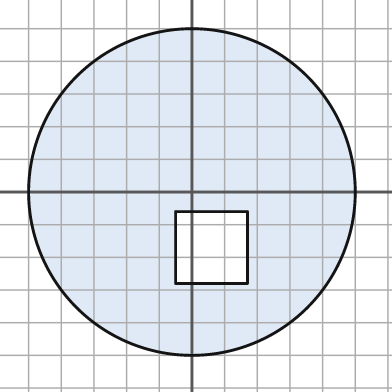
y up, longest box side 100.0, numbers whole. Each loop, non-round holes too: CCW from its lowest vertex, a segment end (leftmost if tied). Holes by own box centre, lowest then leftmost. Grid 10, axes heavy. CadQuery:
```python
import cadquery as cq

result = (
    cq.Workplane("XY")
    .moveTo(0.0, 0.0)
    .circle(50.0)
    .moveTo(-5.0, -28.0)
    .lineTo(17.0, -28.0)
    .lineTo(17.0, -6.0)
    .lineTo(-5.0, -6.0)
    .close()
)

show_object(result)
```